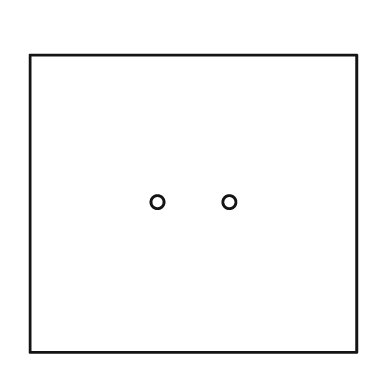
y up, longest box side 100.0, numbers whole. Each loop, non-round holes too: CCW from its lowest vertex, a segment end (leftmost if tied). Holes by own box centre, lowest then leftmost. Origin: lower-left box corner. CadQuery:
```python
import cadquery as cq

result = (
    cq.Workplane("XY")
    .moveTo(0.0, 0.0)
    .lineTo(100.0, 0.0)
    .lineTo(100.0, 91.0)
    .lineTo(0.0, 91.0)
    .close()
    .moveTo(39.0, 46.0)
    .circle(2.0)
    .moveTo(61.0, 46.0)
    .circle(2.0)
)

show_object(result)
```